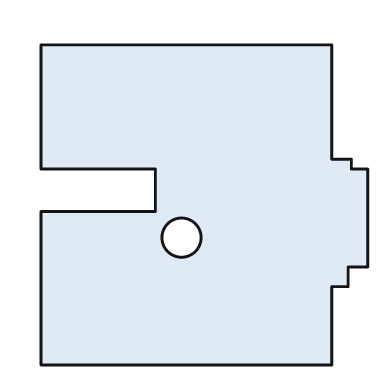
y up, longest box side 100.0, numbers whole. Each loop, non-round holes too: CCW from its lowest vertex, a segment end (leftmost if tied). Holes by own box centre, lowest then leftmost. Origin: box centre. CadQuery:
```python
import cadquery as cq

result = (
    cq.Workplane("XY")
    .moveTo(-50.0, -49.0)
    .lineTo(39.0, -49.0)
    .lineTo(39.0, -25.0)
    .lineTo(44.0, -25.0)
    .lineTo(44.0, -19.0)
    .lineTo(50.0, -19.0)
    .lineTo(50.0, 11.0)
    .lineTo(45.0, 11.0)
    .lineTo(45.0, 14.0)
    .lineTo(39.0, 14.0)
    .lineTo(39.0, 49.0)
    .lineTo(-50.0, 49.0)
    .lineTo(-50.0, 11.0)
    .lineTo(-15.0, 11.0)
    .lineTo(-15.0, -2.0)
    .lineTo(-50.0, -2.0)
    .close()
    .moveTo(-7.0, -10.0)
    .circle(6.0)
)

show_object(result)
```